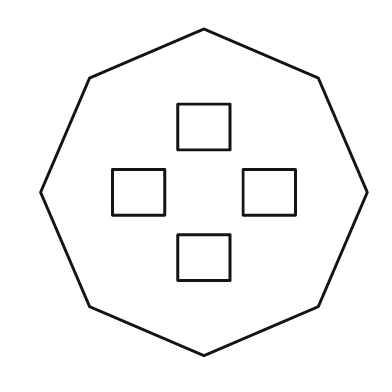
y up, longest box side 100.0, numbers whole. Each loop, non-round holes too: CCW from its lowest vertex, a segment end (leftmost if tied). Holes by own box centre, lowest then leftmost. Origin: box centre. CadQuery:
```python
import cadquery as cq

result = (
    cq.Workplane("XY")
    .moveTo(0.0, -50.0)
    .lineTo(35.0, -35.0)
    .lineTo(50.0, 0.0)
    .lineTo(35.0, 35.0)
    .lineTo(0.0, 50.0)
    .lineTo(-35.0, 35.0)
    .lineTo(-50.0, 0.0)
    .lineTo(-35.0, -35.0)
    .close()
    .moveTo(-8.0, -27.0)
    .lineTo(8.0, -27.0)
    .lineTo(8.0, -13.0)
    .lineTo(-8.0, -13.0)
    .close()
    .moveTo(-28.0, -7.0)
    .lineTo(-12.0, -7.0)
    .lineTo(-12.0, 7.0)
    .lineTo(-28.0, 7.0)
    .close()
    .moveTo(12.0, -7.0)
    .lineTo(28.0, -7.0)
    .lineTo(28.0, 7.0)
    .lineTo(12.0, 7.0)
    .close()
    .moveTo(-8.0, 13.0)
    .lineTo(8.0, 13.0)
    .lineTo(8.0, 27.0)
    .lineTo(-8.0, 27.0)
    .close()
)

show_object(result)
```